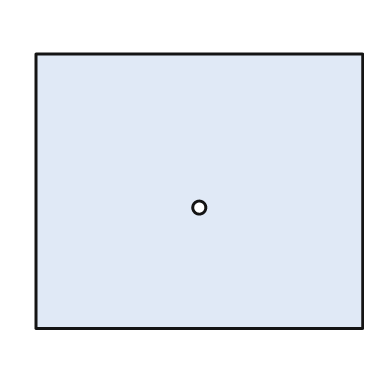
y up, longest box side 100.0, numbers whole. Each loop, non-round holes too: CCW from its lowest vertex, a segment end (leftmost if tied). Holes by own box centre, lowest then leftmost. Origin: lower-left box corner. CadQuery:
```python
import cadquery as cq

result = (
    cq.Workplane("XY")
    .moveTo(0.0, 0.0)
    .lineTo(100.0, 0.0)
    .lineTo(100.0, 84.0)
    .lineTo(0.0, 84.0)
    .close()
    .moveTo(50.0, 37.0)
    .circle(2.0)
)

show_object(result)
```